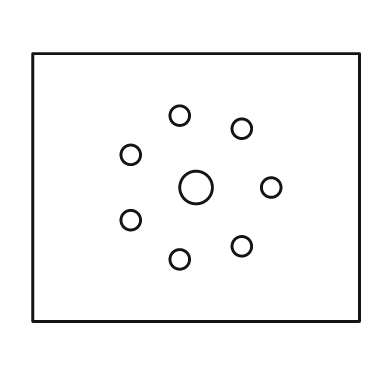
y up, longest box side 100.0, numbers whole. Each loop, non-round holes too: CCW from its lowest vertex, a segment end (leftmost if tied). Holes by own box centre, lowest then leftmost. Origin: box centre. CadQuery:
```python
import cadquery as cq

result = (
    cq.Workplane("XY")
    .moveTo(-50.0, -41.0)
    .lineTo(50.0, -41.0)
    .lineTo(50.0, 41.0)
    .lineTo(-50.0, 41.0)
    .close()
    .moveTo(-5.0, -22.0)
    .circle(3.0)
    .moveTo(14.0, -18.0)
    .circle(3.0)
    .moveTo(-20.0, -10.0)
    .circle(3.0)
    .moveTo(0.0, 0.0)
    .circle(5.0)
    .moveTo(23.0, 0.0)
    .circle(3.0)
    .moveTo(-20.0, 10.0)
    .circle(3.0)
    .moveTo(14.0, 18.0)
    .circle(3.0)
    .moveTo(-5.0, 22.0)
    .circle(3.0)
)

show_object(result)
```